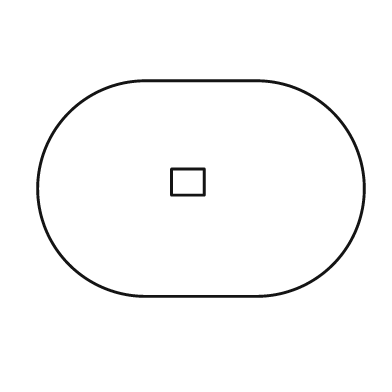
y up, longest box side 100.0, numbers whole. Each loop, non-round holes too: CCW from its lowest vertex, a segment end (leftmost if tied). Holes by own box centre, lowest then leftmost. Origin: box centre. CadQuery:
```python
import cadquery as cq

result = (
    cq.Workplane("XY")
    .moveTo(-17.0, -33.0)
    .lineTo(17.0, -33.0)
    .threePointArc((50.0, 0.0), (17.0, 33.0))
    .lineTo(-17.0, 33.0)
    .threePointArc((-50.0, 0.0), (-17.0, -33.0))
    .close()
    .moveTo(-9.0, -2.0)
    .lineTo(1.0, -2.0)
    .lineTo(1.0, 6.0)
    .lineTo(-9.0, 6.0)
    .close()
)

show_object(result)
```